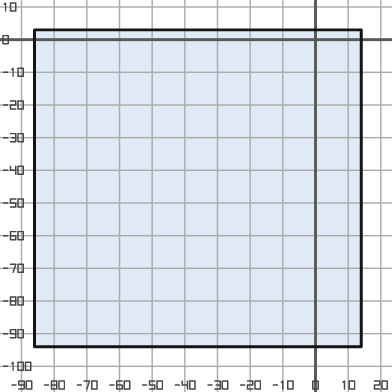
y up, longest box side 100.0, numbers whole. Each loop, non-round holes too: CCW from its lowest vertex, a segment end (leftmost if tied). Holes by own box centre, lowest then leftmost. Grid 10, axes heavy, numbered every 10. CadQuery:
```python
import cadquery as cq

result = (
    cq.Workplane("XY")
    .moveTo(-86.0, -94.0)
    .lineTo(14.0, -94.0)
    .lineTo(14.0, 3.0)
    .lineTo(-86.0, 3.0)
    .close()
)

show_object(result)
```